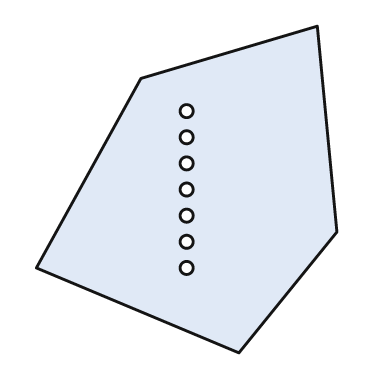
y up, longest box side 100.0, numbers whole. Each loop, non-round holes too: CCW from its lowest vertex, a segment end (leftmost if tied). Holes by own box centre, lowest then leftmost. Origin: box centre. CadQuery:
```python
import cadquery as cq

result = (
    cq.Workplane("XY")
    .moveTo(16.0, -50.0)
    .lineTo(46.0, -13.0)
    .lineTo(40.0, 50.0)
    .lineTo(-14.0, 34.0)
    .lineTo(-46.0, -24.0)
    .close()
    .moveTo(0.0, -24.0)
    .circle(2.0)
    .moveTo(0.0, -16.0)
    .circle(2.0)
    .moveTo(0.0, -8.0)
    .circle(2.0)
    .moveTo(0.0, 0.0)
    .circle(2.0)
    .moveTo(0.0, 8.0)
    .circle(2.0)
    .moveTo(0.0, 16.0)
    .circle(2.0)
    .moveTo(0.0, 24.0)
    .circle(2.0)
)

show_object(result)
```